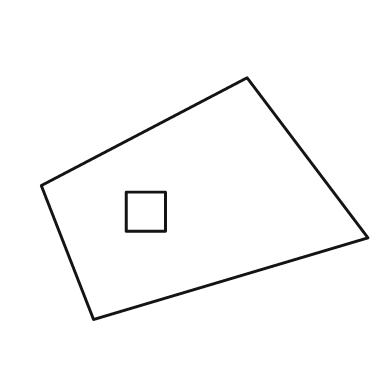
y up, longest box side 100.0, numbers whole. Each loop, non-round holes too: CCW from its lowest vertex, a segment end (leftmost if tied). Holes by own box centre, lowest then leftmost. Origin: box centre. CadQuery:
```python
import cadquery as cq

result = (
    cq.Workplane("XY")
    .moveTo(-34.0, -37.0)
    .lineTo(50.0, -12.0)
    .lineTo(13.0, 37.0)
    .lineTo(-50.0, 4.0)
    .close()
    .moveTo(-24.0, -10.0)
    .lineTo(-12.0, -10.0)
    .lineTo(-12.0, 2.0)
    .lineTo(-24.0, 2.0)
    .close()
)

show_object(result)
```